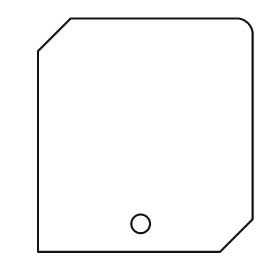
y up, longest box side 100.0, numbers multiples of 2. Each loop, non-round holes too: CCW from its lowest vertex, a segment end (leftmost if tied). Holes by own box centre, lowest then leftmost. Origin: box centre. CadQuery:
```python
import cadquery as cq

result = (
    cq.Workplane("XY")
    .moveTo(-46.0, -50.0)
    .lineTo(32.0, -50.0)
    .lineTo(46.0, -36.0)
    .lineTo(46.0, 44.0)
    .threePointArc((44.0, 48.0), (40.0, 50.0))
    .lineTo(-32.0, 50.0)
    .lineTo(-46.0, 36.0)
    .close()
    .moveTo(-2.0, -38.0)
    .circle(4.0)
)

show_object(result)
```